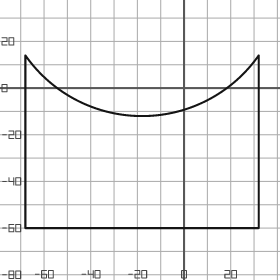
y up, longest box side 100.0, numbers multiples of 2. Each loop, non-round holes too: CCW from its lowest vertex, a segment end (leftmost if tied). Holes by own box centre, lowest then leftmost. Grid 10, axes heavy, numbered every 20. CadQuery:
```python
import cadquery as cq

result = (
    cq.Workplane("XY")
    .moveTo(-68.0, -60.0)
    .lineTo(32.0, -60.0)
    .lineTo(32.0, 14.0)
    .threePointArc((-18.0, -12.0), (-68.0, 14.0))
    .close()
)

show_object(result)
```